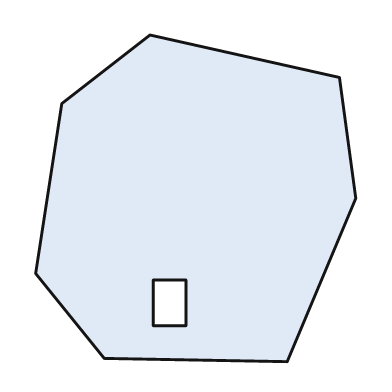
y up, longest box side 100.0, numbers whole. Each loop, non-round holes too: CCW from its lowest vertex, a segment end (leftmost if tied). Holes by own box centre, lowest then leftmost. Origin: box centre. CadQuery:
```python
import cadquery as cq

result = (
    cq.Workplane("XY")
    .moveTo(28.0, -50.0)
    .lineTo(49.0, 0.0)
    .lineTo(44.0, 37.0)
    .lineTo(-14.0, 50.0)
    .lineTo(-41.0, 29.0)
    .lineTo(-49.0, -23.0)
    .lineTo(-28.0, -49.0)
    .close()
    .moveTo(-13.0, -39.0)
    .lineTo(-3.0, -39.0)
    .lineTo(-3.0, -25.0)
    .lineTo(-13.0, -25.0)
    .close()
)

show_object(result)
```